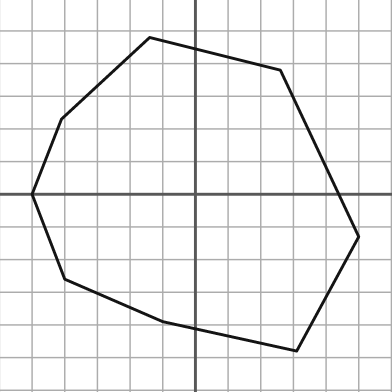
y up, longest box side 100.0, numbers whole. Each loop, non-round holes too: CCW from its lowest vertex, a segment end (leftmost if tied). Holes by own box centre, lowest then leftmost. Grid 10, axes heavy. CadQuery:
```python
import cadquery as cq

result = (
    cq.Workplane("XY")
    .moveTo(31.0, -48.0)
    .lineTo(50.0, -13.0)
    .lineTo(26.0, 38.0)
    .lineTo(-14.0, 48.0)
    .lineTo(-41.0, 23.0)
    .lineTo(-50.0, 0.0)
    .lineTo(-40.0, -26.0)
    .lineTo(-10.0, -39.0)
    .close()
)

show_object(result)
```